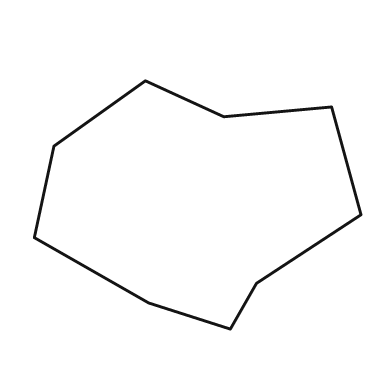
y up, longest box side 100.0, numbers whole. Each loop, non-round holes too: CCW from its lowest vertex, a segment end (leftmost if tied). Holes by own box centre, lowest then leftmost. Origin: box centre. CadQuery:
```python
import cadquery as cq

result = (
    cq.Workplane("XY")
    .moveTo(10.0, -38.0)
    .lineTo(18.0, -24.0)
    .lineTo(50.0, -3.0)
    .lineTo(41.0, 30.0)
    .lineTo(8.0, 27.0)
    .lineTo(-16.0, 38.0)
    .lineTo(-44.0, 18.0)
    .lineTo(-50.0, -10.0)
    .lineTo(-15.0, -30.0)
    .close()
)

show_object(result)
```